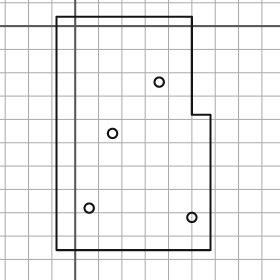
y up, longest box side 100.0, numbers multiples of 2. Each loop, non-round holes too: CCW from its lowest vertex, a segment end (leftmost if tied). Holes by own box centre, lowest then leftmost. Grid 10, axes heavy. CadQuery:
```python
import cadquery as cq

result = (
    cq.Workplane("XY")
    .moveTo(-8.0, -96.0)
    .lineTo(58.0, -96.0)
    .lineTo(58.0, -38.0)
    .lineTo(50.0, -38.0)
    .lineTo(50.0, 4.0)
    .lineTo(-8.0, 4.0)
    .close()
    .moveTo(50.0, -82.0)
    .circle(2.0)
    .moveTo(6.0, -78.0)
    .circle(2.0)
    .moveTo(16.0, -46.0)
    .circle(2.0)
    .moveTo(36.0, -24.0)
    .circle(2.0)
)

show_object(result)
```